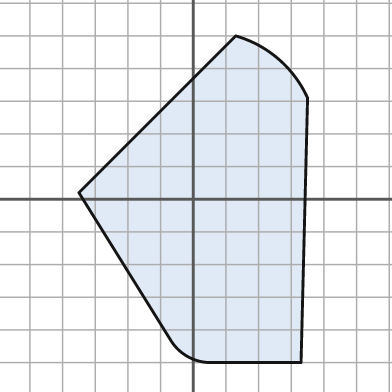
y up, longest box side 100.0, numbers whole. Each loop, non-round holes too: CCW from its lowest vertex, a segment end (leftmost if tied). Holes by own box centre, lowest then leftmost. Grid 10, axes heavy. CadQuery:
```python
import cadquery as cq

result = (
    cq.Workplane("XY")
    .moveTo(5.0, -50.0)
    .lineTo(33.0, -50.0)
    .lineTo(35.0, 31.0)
    .threePointArc((26.0, 43.0), (13.0, 50.0))
    .lineTo(-35.0, 2.0)
    .lineTo(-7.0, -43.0)
    .threePointArc((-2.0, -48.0), (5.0, -50.0))
    .close()
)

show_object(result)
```